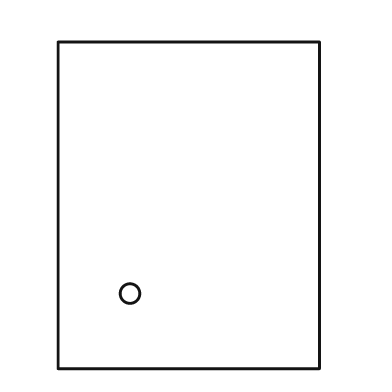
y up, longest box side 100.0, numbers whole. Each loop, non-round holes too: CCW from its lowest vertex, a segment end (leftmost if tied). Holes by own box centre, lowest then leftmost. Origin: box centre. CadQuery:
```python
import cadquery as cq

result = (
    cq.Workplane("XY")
    .moveTo(-40.0, -50.0)
    .lineTo(40.0, -50.0)
    .lineTo(40.0, 50.0)
    .lineTo(-40.0, 50.0)
    .close()
    .moveTo(-18.0, -27.0)
    .circle(3.0)
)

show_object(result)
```